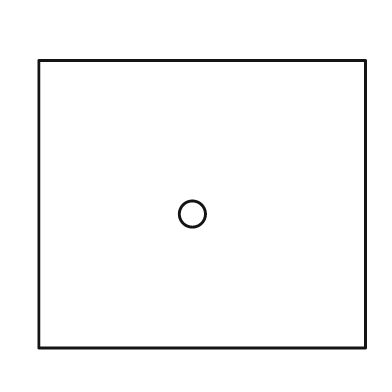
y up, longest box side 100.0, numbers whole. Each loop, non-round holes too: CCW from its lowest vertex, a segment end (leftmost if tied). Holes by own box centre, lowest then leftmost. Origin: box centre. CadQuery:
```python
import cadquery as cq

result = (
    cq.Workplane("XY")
    .moveTo(-50.0, -44.0)
    .lineTo(50.0, -44.0)
    .lineTo(50.0, 44.0)
    .lineTo(-50.0, 44.0)
    .close()
    .moveTo(-3.0, -3.0)
    .circle(4.0)
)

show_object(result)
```